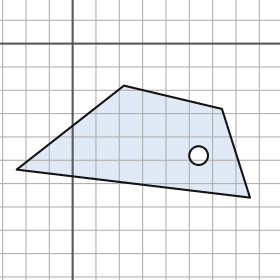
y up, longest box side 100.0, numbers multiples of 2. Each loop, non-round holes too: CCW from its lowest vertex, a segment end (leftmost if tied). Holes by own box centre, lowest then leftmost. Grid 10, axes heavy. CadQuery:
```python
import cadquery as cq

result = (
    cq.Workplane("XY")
    .moveTo(76.0, -66.0)
    .lineTo(64.0, -28.0)
    .lineTo(22.0, -18.0)
    .lineTo(-24.0, -54.0)
    .close()
    .moveTo(54.0, -48.0)
    .circle(4.0)
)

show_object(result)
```